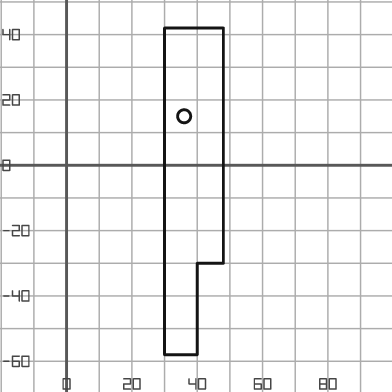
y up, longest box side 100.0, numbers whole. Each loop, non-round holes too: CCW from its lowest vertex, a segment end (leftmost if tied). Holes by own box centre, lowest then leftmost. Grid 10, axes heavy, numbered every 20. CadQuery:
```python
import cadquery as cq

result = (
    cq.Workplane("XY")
    .moveTo(30.0, -58.0)
    .lineTo(40.0, -58.0)
    .lineTo(40.0, -30.0)
    .lineTo(48.0, -30.0)
    .lineTo(48.0, 42.0)
    .lineTo(30.0, 42.0)
    .close()
    .moveTo(36.0, 15.0)
    .circle(2.0)
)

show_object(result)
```